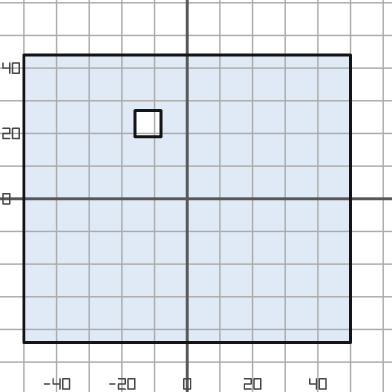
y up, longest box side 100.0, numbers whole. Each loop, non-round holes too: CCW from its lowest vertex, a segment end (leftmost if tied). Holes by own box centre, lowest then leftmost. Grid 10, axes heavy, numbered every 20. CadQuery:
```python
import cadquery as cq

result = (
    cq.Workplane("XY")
    .moveTo(-50.0, -44.0)
    .lineTo(50.0, -44.0)
    .lineTo(50.0, 44.0)
    .lineTo(-50.0, 44.0)
    .close()
    .moveTo(-16.0, 19.0)
    .lineTo(-8.0, 19.0)
    .lineTo(-8.0, 27.0)
    .lineTo(-16.0, 27.0)
    .close()
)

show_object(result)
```